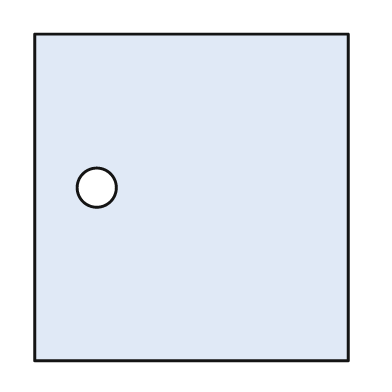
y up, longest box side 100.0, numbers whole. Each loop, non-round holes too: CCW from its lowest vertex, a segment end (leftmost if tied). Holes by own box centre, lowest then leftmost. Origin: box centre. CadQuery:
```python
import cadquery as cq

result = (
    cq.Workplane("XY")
    .moveTo(-48.0, -50.0)
    .lineTo(48.0, -50.0)
    .lineTo(48.0, 50.0)
    .lineTo(-48.0, 50.0)
    .close()
    .moveTo(-29.0, 3.0)
    .circle(6.0)
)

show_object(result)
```